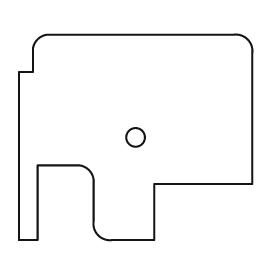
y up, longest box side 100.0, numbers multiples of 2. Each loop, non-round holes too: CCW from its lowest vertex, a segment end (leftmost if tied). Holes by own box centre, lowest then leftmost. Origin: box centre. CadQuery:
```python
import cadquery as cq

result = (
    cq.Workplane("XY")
    .moveTo(-50.0, -44.0)
    .lineTo(-42.0, -44.0)
    .lineTo(-42.0, -12.0)
    .lineTo(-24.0, -12.0)
    .threePointArc((-20.0, -14.0), (-18.0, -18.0))
    .lineTo(-18.0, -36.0)
    .threePointArc((-16.0, -42.0), (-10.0, -44.0))
    .lineTo(8.0, -44.0)
    .lineTo(8.0, -20.0)
    .lineTo(50.0, -20.0)
    .lineTo(50.0, 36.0)
    .threePointArc((48.0, 42.0), (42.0, 44.0))
    .lineTo(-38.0, 44.0)
    .threePointArc((-42.0, 42.0), (-44.0, 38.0))
    .lineTo(-44.0, 28.0)
    .lineTo(-50.0, 28.0)
    .close()
    .moveTo(0.0, 0.0)
    .circle(4.0)
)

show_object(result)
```